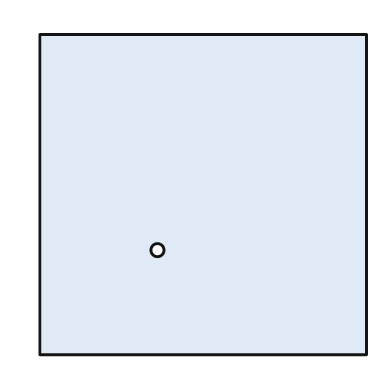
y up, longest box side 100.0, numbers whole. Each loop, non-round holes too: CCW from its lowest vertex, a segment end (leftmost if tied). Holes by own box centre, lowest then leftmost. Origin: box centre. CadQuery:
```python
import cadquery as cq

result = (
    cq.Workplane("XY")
    .moveTo(-50.0, -49.0)
    .lineTo(50.0, -49.0)
    .lineTo(50.0, 49.0)
    .lineTo(-50.0, 49.0)
    .close()
    .moveTo(-14.0, -17.0)
    .circle(2.0)
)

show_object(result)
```